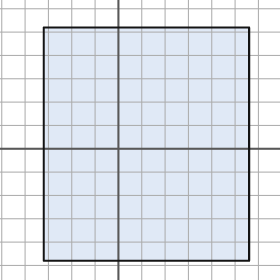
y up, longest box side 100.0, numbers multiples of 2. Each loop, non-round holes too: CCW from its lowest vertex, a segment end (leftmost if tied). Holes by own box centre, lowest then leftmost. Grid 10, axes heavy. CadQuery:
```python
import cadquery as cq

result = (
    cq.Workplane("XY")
    .moveTo(-32.0, -48.0)
    .lineTo(56.0, -48.0)
    .lineTo(56.0, 52.0)
    .lineTo(-32.0, 52.0)
    .close()
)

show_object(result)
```